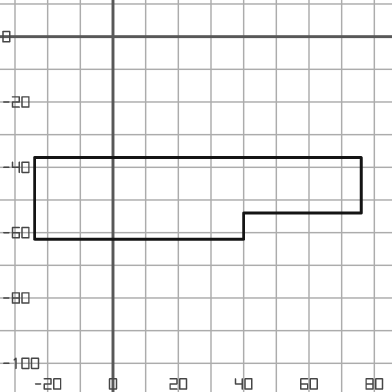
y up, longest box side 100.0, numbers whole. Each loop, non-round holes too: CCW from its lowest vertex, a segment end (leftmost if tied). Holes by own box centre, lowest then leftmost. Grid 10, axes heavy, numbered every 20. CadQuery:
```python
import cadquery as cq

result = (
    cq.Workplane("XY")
    .moveTo(-24.0, -62.0)
    .lineTo(40.0, -62.0)
    .lineTo(40.0, -54.0)
    .lineTo(76.0, -54.0)
    .lineTo(76.0, -37.0)
    .lineTo(-24.0, -37.0)
    .close()
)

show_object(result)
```